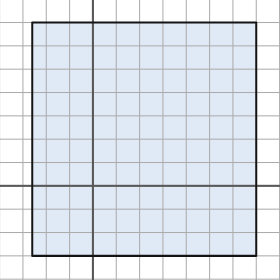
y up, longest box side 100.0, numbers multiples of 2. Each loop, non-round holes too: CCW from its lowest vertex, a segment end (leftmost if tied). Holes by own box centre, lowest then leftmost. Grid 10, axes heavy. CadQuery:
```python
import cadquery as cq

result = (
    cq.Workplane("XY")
    .moveTo(-26.0, -30.0)
    .lineTo(70.0, -30.0)
    .lineTo(70.0, 70.0)
    .lineTo(-26.0, 70.0)
    .close()
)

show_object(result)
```